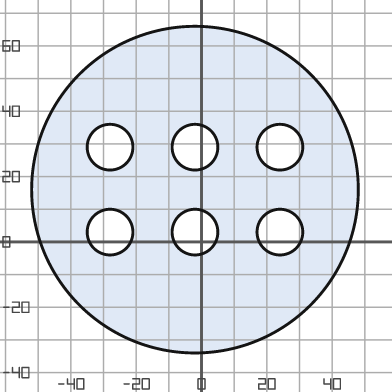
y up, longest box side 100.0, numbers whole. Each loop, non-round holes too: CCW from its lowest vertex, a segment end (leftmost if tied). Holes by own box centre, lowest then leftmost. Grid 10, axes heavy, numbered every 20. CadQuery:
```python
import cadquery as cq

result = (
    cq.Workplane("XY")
    .moveTo(-2.0, 16.0)
    .circle(50.0)
    .moveTo(-28.0, 3.0)
    .circle(7.0)
    .moveTo(-2.0, 3.0)
    .circle(7.0)
    .moveTo(24.0, 3.0)
    .circle(7.0)
    .moveTo(-28.0, 29.0)
    .circle(7.0)
    .moveTo(-2.0, 29.0)
    .circle(7.0)
    .moveTo(24.0, 29.0)
    .circle(7.0)
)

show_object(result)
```